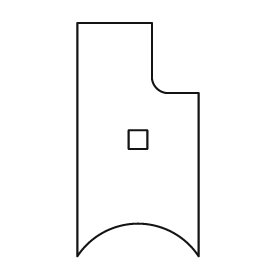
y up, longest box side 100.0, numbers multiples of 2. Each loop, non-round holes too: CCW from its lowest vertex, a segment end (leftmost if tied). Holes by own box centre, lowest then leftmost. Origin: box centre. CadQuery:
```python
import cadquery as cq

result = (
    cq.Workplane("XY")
    .moveTo(-26.0, -50.0)
    .threePointArc((0.0, -36.0), (26.0, -50.0))
    .lineTo(26.0, 20.0)
    .lineTo(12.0, 20.0)
    .threePointArc((8.0, 22.0), (6.0, 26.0))
    .lineTo(6.0, 50.0)
    .lineTo(-26.0, 50.0)
    .close()
    .moveTo(-4.0, -4.0)
    .lineTo(4.0, -4.0)
    .lineTo(4.0, 4.0)
    .lineTo(-4.0, 4.0)
    .close()
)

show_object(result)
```